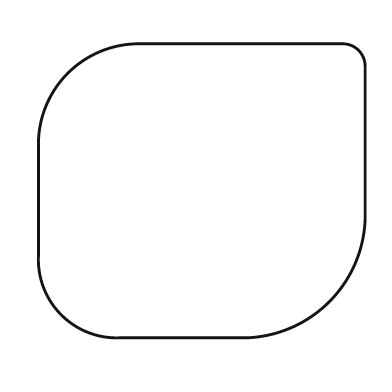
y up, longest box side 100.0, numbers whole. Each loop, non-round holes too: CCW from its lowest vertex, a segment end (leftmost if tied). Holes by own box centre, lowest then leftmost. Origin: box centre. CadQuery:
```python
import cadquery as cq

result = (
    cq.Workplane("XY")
    .moveTo(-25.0, -45.0)
    .lineTo(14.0, -45.0)
    .threePointArc((39.0, -34.0), (50.0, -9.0))
    .lineTo(50.0, 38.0)
    .threePointArc((48.0, 43.0), (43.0, 45.0))
    .lineTo(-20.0, 45.0)
    .threePointArc((-41.0, 36.0), (-50.0, 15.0))
    .lineTo(-50.0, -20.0)
    .threePointArc((-43.0, -38.0), (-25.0, -45.0))
    .close()
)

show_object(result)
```